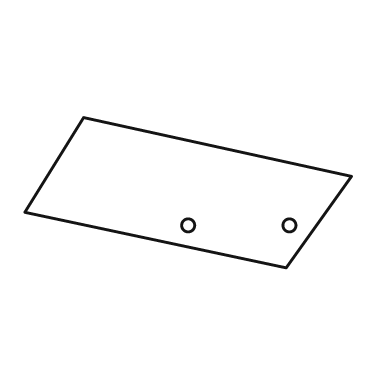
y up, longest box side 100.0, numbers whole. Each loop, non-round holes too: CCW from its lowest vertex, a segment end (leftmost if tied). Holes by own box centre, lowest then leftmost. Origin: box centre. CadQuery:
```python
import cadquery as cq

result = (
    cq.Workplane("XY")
    .moveTo(30.0, -23.0)
    .lineTo(50.0, 5.0)
    .lineTo(-32.0, 23.0)
    .lineTo(-50.0, -6.0)
    .close()
    .moveTo(0.0, -10.0)
    .circle(2.0)
    .moveTo(31.0, -10.0)
    .circle(2.0)
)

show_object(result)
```